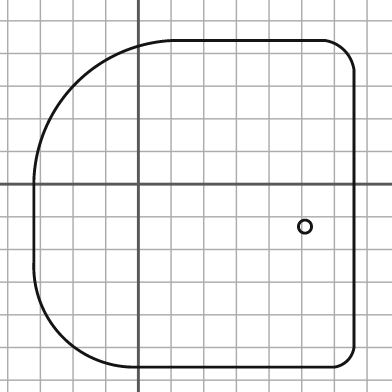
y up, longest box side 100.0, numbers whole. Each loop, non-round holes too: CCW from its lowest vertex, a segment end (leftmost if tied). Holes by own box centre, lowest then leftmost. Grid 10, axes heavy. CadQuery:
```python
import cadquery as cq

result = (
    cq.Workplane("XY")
    .moveTo(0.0, -56.0)
    .lineTo(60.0, -56.0)
    .threePointArc((64.0, -54.0), (66.0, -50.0))
    .lineTo(66.0, 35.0)
    .threePointArc((63.0, 41.0), (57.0, 44.0))
    .lineTo(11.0, 44.0)
    .threePointArc((-19.0, 31.0), (-32.0, 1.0))
    .lineTo(-32.0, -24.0)
    .threePointArc((-23.0, -47.0), (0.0, -56.0))
    .close()
    .moveTo(51.0, -13.0)
    .circle(2.0)
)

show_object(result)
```